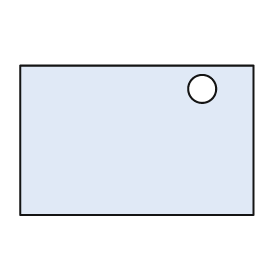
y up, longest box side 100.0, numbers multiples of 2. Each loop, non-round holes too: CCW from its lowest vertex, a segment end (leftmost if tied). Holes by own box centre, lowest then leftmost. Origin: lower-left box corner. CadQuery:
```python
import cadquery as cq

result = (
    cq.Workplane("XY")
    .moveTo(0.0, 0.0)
    .lineTo(100.0, 0.0)
    .lineTo(100.0, 64.0)
    .lineTo(0.0, 64.0)
    .close()
    .moveTo(78.0, 54.0)
    .circle(6.0)
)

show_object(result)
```